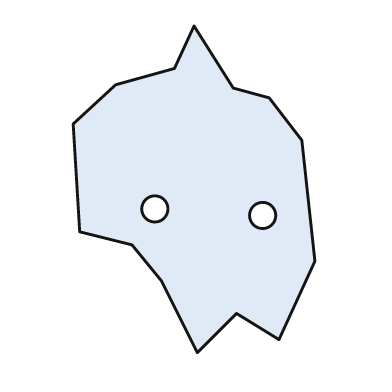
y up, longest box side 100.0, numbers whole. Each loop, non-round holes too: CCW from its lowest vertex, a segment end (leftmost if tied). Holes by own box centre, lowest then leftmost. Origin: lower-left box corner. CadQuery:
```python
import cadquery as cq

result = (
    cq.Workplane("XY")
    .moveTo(38.0, 0.0)
    .lineTo(50.0, 12.0)
    .lineTo(63.0, 4.0)
    .lineTo(74.0, 28.0)
    .lineTo(70.0, 65.0)
    .lineTo(60.0, 78.0)
    .lineTo(49.0, 81.0)
    .lineTo(37.0, 100.0)
    .lineTo(31.0, 87.0)
    .lineTo(13.0, 82.0)
    .lineTo(0.0, 70.0)
    .lineTo(2.0, 37.0)
    .lineTo(18.0, 33.0)
    .lineTo(27.0, 22.0)
    .close()
    .moveTo(58.0, 42.0)
    .circle(4.0)
    .moveTo(25.0, 44.0)
    .circle(4.0)
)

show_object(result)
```